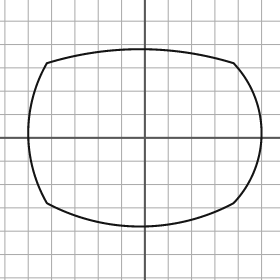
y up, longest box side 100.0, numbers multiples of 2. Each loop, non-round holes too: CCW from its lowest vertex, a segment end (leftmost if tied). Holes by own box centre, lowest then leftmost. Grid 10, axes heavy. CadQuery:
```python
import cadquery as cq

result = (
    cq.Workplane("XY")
    .moveTo(-42.0, -28.0)
    .threePointArc((-2.0, -38.0), (38.0, -28.0))
    .threePointArc((50.0, 2.0), (38.0, 32.0))
    .threePointArc((-2.0, 38.0), (-42.0, 32.0))
    .threePointArc((-50.0, 2.0), (-42.0, -28.0))
    .close()
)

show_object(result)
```